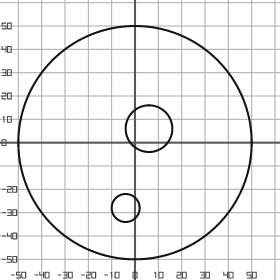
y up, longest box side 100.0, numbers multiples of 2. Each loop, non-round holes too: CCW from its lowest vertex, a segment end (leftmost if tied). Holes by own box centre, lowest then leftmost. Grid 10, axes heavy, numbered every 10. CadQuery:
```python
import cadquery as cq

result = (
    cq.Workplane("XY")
    .moveTo(0.0, 0.0)
    .circle(50.0)
    .moveTo(-4.0, -28.0)
    .circle(6.0)
    .moveTo(6.0, 6.0)
    .circle(10.0)
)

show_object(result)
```